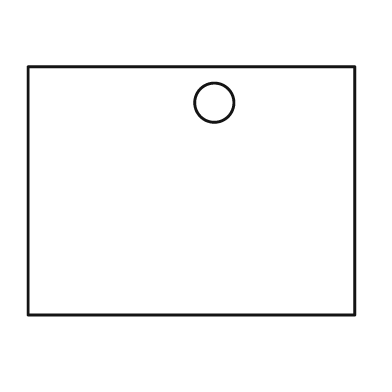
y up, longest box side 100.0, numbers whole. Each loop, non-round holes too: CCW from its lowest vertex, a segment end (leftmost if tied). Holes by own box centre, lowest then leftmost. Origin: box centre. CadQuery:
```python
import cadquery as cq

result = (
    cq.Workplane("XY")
    .moveTo(-50.0, -38.0)
    .lineTo(50.0, -38.0)
    .lineTo(50.0, 38.0)
    .lineTo(-50.0, 38.0)
    .close()
    .moveTo(7.0, 27.0)
    .circle(6.0)
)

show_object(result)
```